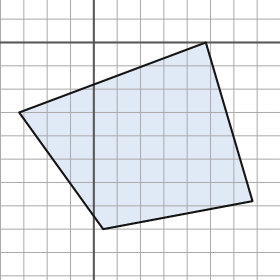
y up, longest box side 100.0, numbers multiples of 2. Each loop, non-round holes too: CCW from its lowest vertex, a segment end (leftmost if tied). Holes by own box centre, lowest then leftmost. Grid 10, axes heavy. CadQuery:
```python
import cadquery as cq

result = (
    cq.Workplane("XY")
    .moveTo(4.0, -80.0)
    .lineTo(68.0, -68.0)
    .lineTo(48.0, 0.0)
    .lineTo(-32.0, -30.0)
    .close()
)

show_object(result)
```